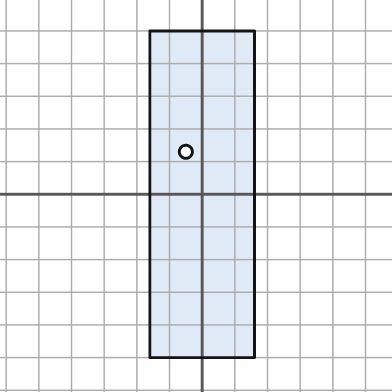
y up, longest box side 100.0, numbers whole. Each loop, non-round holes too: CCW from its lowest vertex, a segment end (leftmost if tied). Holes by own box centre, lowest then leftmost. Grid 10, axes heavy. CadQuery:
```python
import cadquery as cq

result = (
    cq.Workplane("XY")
    .moveTo(-16.0, -50.0)
    .lineTo(16.0, -50.0)
    .lineTo(16.0, 50.0)
    .lineTo(-16.0, 50.0)
    .close()
    .moveTo(-5.0, 13.0)
    .circle(2.0)
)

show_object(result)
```